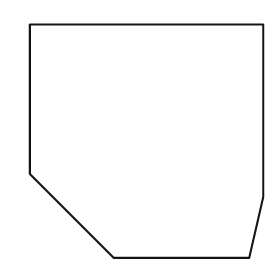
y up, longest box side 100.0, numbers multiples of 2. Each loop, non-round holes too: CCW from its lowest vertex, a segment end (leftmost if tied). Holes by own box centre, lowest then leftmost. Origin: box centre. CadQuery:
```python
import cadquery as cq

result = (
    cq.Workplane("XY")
    .moveTo(-14.0, -50.0)
    .lineTo(44.0, -50.0)
    .lineTo(50.0, -24.0)
    .lineTo(50.0, 50.0)
    .lineTo(-50.0, 50.0)
    .lineTo(-50.0, -14.0)
    .close()
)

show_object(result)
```